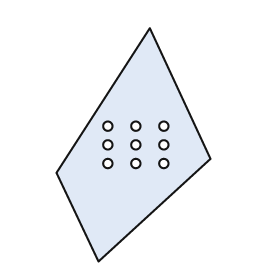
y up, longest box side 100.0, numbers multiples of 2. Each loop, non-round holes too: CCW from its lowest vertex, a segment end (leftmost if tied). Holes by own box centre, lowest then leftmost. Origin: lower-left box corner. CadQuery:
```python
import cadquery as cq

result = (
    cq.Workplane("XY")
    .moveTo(18.0, 0.0)
    .lineTo(66.0, 44.0)
    .lineTo(40.0, 100.0)
    .lineTo(0.0, 38.0)
    .close()
    .moveTo(22.0, 42.0)
    .circle(2.0)
    .moveTo(34.0, 42.0)
    .circle(2.0)
    .moveTo(46.0, 42.0)
    .circle(2.0)
    .moveTo(22.0, 50.0)
    .circle(2.0)
    .moveTo(34.0, 50.0)
    .circle(2.0)
    .moveTo(46.0, 50.0)
    .circle(2.0)
    .moveTo(22.0, 58.0)
    .circle(2.0)
    .moveTo(34.0, 58.0)
    .circle(2.0)
    .moveTo(46.0, 58.0)
    .circle(2.0)
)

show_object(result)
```